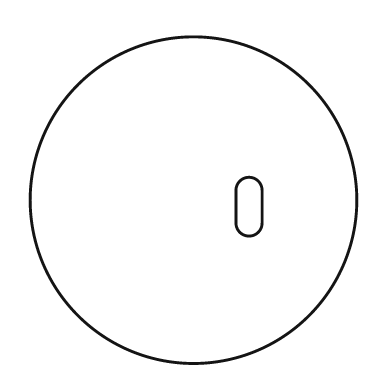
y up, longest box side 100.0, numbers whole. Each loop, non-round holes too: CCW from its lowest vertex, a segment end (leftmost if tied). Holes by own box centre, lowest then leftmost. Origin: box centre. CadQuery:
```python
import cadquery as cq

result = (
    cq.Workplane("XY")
    .moveTo(0.0, 0.0)
    .circle(50.0)
    .moveTo(13.0, -7.0)
    .threePointArc((17.0, -11.0), (21.0, -7.0))
    .lineTo(21.0, 3.0)
    .threePointArc((17.0, 7.0), (13.0, 3.0))
    .close()
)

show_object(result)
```